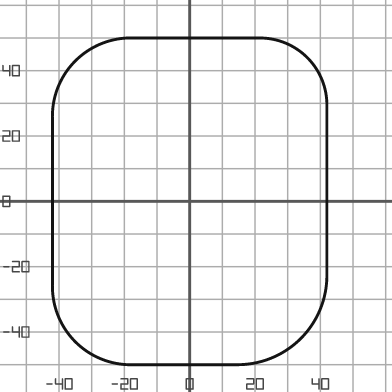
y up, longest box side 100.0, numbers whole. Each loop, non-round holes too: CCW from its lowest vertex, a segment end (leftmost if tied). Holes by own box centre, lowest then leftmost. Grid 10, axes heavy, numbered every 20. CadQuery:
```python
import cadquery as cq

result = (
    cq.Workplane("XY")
    .moveTo(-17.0, -50.0)
    .lineTo(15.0, -50.0)
    .threePointArc((34.0, -42.0), (42.0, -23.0))
    .lineTo(42.0, 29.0)
    .threePointArc((36.0, 44.0), (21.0, 50.0))
    .lineTo(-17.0, 50.0)
    .threePointArc((-35.0, 43.0), (-42.0, 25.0))
    .lineTo(-42.0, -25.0)
    .threePointArc((-35.0, -43.0), (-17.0, -50.0))
    .close()
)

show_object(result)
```